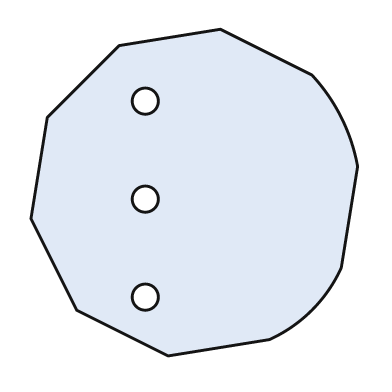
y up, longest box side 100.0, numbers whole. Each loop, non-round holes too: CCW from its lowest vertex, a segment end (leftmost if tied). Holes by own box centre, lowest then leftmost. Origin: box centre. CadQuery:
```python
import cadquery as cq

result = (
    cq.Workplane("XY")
    .moveTo(-8.0, -50.0)
    .lineTo(23.0, -45.0)
    .threePointArc((36.0, -36.0), (45.0, -23.0))
    .lineTo(50.0, 8.0)
    .threePointArc((45.0, 23.0), (36.0, 36.0))
    .lineTo(8.0, 50.0)
    .lineTo(-23.0, 45.0)
    .lineTo(-45.0, 23.0)
    .lineTo(-50.0, -8.0)
    .lineTo(-36.0, -36.0)
    .close()
    .moveTo(-15.0, -32.0)
    .circle(4.0)
    .moveTo(-15.0, -2.0)
    .circle(4.0)
    .moveTo(-15.0, 28.0)
    .circle(4.0)
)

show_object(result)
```